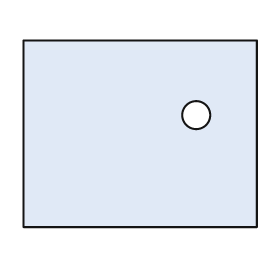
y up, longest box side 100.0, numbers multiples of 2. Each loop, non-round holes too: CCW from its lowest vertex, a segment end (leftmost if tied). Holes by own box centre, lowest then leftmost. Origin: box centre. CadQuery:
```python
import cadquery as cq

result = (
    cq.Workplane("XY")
    .moveTo(-50.0, -40.0)
    .lineTo(50.0, -40.0)
    .lineTo(50.0, 40.0)
    .lineTo(-50.0, 40.0)
    .close()
    .moveTo(24.0, 8.0)
    .circle(6.0)
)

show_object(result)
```